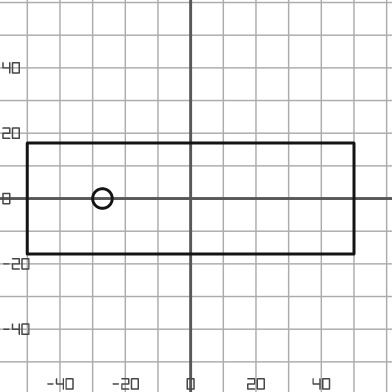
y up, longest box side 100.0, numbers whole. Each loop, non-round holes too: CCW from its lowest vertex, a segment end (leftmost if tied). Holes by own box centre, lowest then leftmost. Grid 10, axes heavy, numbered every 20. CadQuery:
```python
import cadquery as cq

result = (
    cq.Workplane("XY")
    .moveTo(-50.0, -17.0)
    .lineTo(50.0, -17.0)
    .lineTo(50.0, 17.0)
    .lineTo(-50.0, 17.0)
    .close()
    .moveTo(-27.0, 0.0)
    .circle(3.0)
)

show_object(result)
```